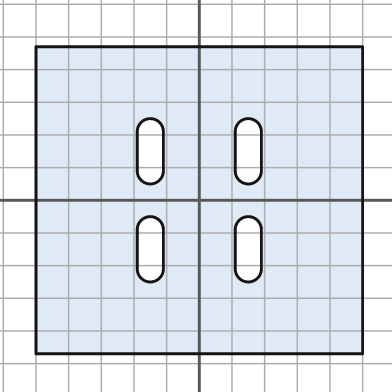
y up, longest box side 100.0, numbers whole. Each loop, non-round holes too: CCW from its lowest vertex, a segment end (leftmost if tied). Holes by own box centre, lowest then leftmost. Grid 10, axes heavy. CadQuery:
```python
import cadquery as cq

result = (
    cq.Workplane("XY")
    .moveTo(-50.0, -47.0)
    .lineTo(50.0, -47.0)
    .lineTo(50.0, 47.0)
    .lineTo(-50.0, 47.0)
    .close()
    .moveTo(-19.0, -21.0)
    .threePointArc((-15.0, -25.0), (-11.0, -21.0))
    .lineTo(-11.0, -9.0)
    .threePointArc((-15.0, -5.0), (-19.0, -9.0))
    .close()
    .moveTo(11.0, -21.0)
    .threePointArc((15.0, -25.0), (19.0, -21.0))
    .lineTo(19.0, -9.0)
    .threePointArc((15.0, -5.0), (11.0, -9.0))
    .close()
    .moveTo(-19.0, 9.0)
    .threePointArc((-15.0, 5.0), (-11.0, 9.0))
    .lineTo(-11.0, 21.0)
    .threePointArc((-15.0, 25.0), (-19.0, 21.0))
    .close()
    .moveTo(11.0, 9.0)
    .threePointArc((15.0, 5.0), (19.0, 9.0))
    .lineTo(19.0, 21.0)
    .threePointArc((15.0, 25.0), (11.0, 21.0))
    .close()
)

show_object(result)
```